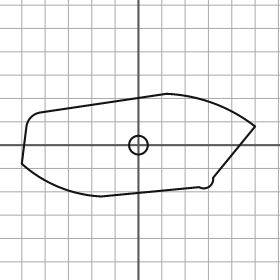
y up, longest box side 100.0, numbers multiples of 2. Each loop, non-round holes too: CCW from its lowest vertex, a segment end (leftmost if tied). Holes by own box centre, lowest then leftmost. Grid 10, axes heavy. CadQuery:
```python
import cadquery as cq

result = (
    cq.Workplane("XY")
    .moveTo(-16.0, -22.0)
    .lineTo(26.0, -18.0)
    .threePointArc((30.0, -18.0), (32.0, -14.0))
    .lineTo(50.0, 8.0)
    .threePointArc((32.0, 18.0), (12.0, 22.0))
    .lineTo(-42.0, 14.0)
    .threePointArc((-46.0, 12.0), (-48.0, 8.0))
    .lineTo(-50.0, -8.0)
    .threePointArc((-34.0, -18.0), (-16.0, -22.0))
    .close()
    .moveTo(0.0, 0.0)
    .circle(4.0)
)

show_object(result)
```